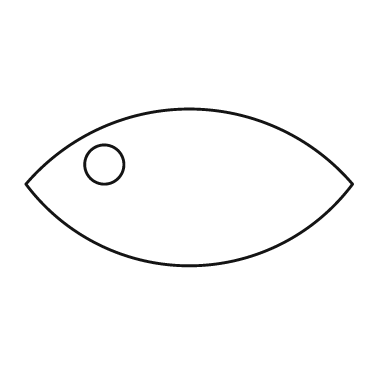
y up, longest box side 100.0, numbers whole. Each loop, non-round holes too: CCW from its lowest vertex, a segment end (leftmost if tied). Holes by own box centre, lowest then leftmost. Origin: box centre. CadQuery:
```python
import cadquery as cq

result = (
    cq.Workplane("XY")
    .moveTo(-50.0, 1.0)
    .threePointArc((0.0, -24.0), (50.0, 1.0))
    .threePointArc((0.0, 24.0), (-50.0, 1.0))
    .close()
    .moveTo(-26.0, 7.0)
    .circle(6.0)
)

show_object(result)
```